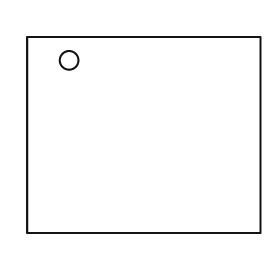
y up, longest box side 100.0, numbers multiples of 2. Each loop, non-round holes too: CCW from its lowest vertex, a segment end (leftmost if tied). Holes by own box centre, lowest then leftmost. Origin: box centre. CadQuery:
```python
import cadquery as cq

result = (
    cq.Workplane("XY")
    .moveTo(-50.0, -42.0)
    .lineTo(50.0, -42.0)
    .lineTo(50.0, 42.0)
    .lineTo(-50.0, 42.0)
    .close()
    .moveTo(-32.0, 32.0)
    .circle(4.0)
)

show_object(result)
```